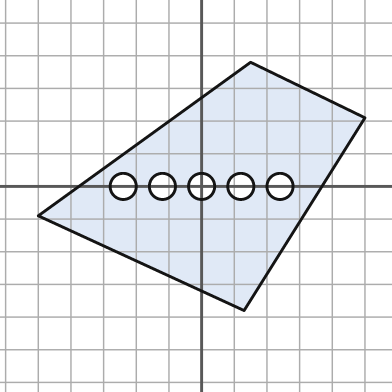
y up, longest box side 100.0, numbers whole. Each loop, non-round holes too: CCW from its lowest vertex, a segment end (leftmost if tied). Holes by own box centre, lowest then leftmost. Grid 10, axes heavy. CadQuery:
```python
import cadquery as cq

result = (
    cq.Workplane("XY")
    .moveTo(13.0, -38.0)
    .lineTo(50.0, 21.0)
    .lineTo(15.0, 38.0)
    .lineTo(-50.0, -9.0)
    .close()
    .moveTo(-24.0, 0.0)
    .circle(4.0)
    .moveTo(-12.0, 0.0)
    .circle(4.0)
    .moveTo(0.0, 0.0)
    .circle(4.0)
    .moveTo(12.0, 0.0)
    .circle(4.0)
    .moveTo(24.0, 0.0)
    .circle(4.0)
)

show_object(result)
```